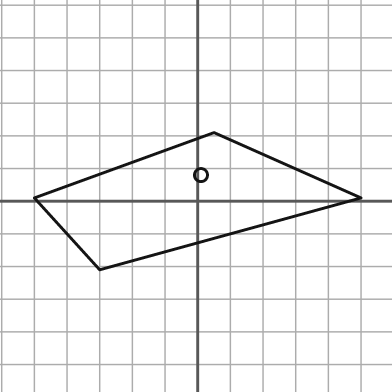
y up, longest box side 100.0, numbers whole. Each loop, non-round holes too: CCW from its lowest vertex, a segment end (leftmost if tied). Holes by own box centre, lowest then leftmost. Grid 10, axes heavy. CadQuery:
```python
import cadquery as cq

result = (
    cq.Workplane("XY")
    .moveTo(-30.0, -21.0)
    .lineTo(50.0, 1.0)
    .lineTo(5.0, 21.0)
    .lineTo(-50.0, 1.0)
    .close()
    .moveTo(1.0, 8.0)
    .circle(2.0)
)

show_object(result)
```